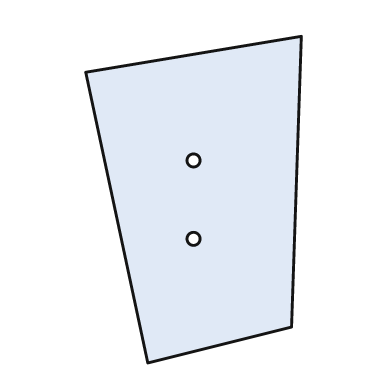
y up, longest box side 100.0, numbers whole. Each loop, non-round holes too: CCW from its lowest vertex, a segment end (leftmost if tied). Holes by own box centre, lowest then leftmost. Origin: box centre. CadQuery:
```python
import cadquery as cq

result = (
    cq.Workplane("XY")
    .moveTo(-14.0, -50.0)
    .lineTo(30.0, -39.0)
    .lineTo(33.0, 50.0)
    .lineTo(-33.0, 39.0)
    .close()
    .moveTo(0.0, -12.0)
    .circle(2.0)
    .moveTo(0.0, 12.0)
    .circle(2.0)
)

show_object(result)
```